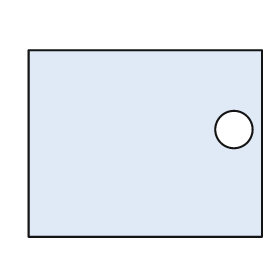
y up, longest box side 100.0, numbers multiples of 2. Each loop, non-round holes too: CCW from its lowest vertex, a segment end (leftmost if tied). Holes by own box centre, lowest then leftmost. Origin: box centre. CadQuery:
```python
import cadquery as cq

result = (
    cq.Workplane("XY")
    .moveTo(-50.0, -40.0)
    .lineTo(50.0, -40.0)
    .lineTo(50.0, 40.0)
    .lineTo(-50.0, 40.0)
    .close()
    .moveTo(38.0, 6.0)
    .circle(8.0)
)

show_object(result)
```